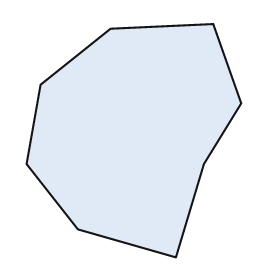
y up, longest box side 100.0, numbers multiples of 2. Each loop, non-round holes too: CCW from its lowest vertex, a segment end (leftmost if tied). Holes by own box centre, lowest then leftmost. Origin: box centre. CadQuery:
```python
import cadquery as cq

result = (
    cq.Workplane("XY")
    .moveTo(18.0, -50.0)
    .lineTo(30.0, -10.0)
    .lineTo(46.0, 16.0)
    .lineTo(34.0, 50.0)
    .lineTo(-10.0, 48.0)
    .lineTo(-40.0, 24.0)
    .lineTo(-46.0, -10.0)
    .lineTo(-24.0, -38.0)
    .close()
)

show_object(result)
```